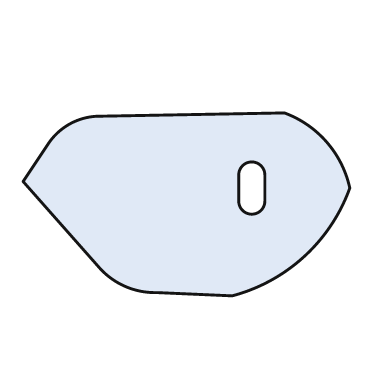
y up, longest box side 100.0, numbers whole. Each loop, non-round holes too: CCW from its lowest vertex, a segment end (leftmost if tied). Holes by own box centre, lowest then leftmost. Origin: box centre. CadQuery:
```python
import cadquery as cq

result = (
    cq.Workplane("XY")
    .moveTo(14.0, -28.0)
    .threePointArc((36.0, -16.0), (50.0, 5.0))
    .threePointArc((43.0, 19.0), (30.0, 28.0))
    .lineTo(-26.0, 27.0)
    .threePointArc((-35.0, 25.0), (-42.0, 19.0))
    .lineTo(-50.0, 7.0)
    .lineTo(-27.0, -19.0)
    .threePointArc((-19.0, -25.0), (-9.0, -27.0))
    .close()
    .moveTo(16.0, 1.0)
    .threePointArc((20.0, -3.0), (24.0, 1.0))
    .lineTo(24.0, 9.0)
    .threePointArc((20.0, 13.0), (16.0, 9.0))
    .close()
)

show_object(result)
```